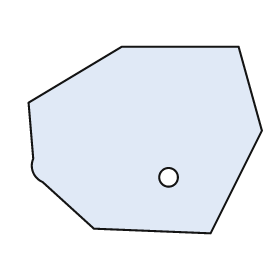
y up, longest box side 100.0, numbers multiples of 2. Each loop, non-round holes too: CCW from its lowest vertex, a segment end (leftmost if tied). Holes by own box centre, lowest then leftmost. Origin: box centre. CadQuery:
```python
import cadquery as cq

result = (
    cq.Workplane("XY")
    .moveTo(28.0, -40.0)
    .lineTo(50.0, 4.0)
    .lineTo(40.0, 40.0)
    .lineTo(-10.0, 40.0)
    .lineTo(-50.0, 16.0)
    .lineTo(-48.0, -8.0)
    .threePointArc((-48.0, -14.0), (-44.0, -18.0))
    .lineTo(-22.0, -38.0)
    .close()
    .moveTo(10.0, -16.0)
    .circle(4.0)
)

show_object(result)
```